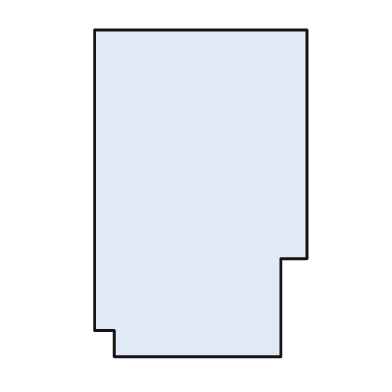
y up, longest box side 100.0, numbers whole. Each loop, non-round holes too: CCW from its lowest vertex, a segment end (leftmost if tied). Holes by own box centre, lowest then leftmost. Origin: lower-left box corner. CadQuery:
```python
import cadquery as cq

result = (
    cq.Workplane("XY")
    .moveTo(6.0, 0.0)
    .lineTo(57.0, 0.0)
    .lineTo(57.0, 30.0)
    .lineTo(65.0, 30.0)
    .lineTo(65.0, 100.0)
    .lineTo(0.0, 100.0)
    .lineTo(0.0, 8.0)
    .lineTo(6.0, 8.0)
    .close()
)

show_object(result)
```